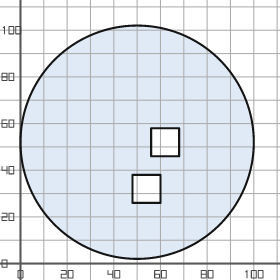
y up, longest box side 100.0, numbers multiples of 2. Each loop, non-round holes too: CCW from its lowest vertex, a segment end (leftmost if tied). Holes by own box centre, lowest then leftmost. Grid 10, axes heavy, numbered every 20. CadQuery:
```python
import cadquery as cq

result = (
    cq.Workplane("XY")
    .moveTo(50.0, 52.0)
    .circle(50.0)
    .moveTo(48.0, 26.0)
    .lineTo(60.0, 26.0)
    .lineTo(60.0, 38.0)
    .lineTo(48.0, 38.0)
    .close()
    .moveTo(56.0, 46.0)
    .lineTo(68.0, 46.0)
    .lineTo(68.0, 58.0)
    .lineTo(56.0, 58.0)
    .close()
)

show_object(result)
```